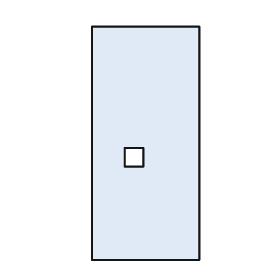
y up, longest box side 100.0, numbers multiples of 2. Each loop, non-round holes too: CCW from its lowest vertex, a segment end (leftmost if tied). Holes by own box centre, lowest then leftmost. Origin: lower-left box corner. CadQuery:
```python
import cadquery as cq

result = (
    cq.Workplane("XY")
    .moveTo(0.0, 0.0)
    .lineTo(46.0, 0.0)
    .lineTo(46.0, 100.0)
    .lineTo(0.0, 100.0)
    .close()
    .moveTo(14.0, 40.0)
    .lineTo(22.0, 40.0)
    .lineTo(22.0, 48.0)
    .lineTo(14.0, 48.0)
    .close()
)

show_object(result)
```